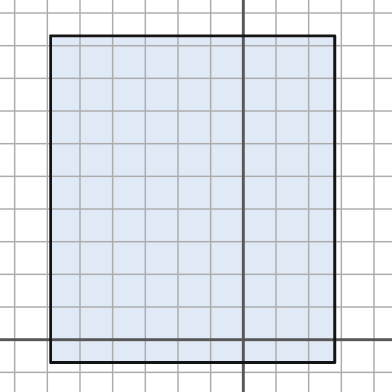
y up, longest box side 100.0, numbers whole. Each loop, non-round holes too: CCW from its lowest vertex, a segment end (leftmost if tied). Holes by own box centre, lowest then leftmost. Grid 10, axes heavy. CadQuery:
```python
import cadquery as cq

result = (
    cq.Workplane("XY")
    .moveTo(-59.0, -7.0)
    .lineTo(28.0, -7.0)
    .lineTo(28.0, 93.0)
    .lineTo(-59.0, 93.0)
    .close()
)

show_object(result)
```